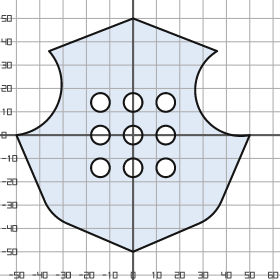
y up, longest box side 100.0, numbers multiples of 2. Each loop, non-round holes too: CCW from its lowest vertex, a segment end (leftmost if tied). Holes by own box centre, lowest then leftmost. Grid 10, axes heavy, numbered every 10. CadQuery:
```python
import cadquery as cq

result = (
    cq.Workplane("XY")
    .moveTo(0.0, -50.0)
    .lineTo(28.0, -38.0)
    .threePointArc((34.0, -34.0), (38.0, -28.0))
    .lineTo(50.0, 0.0)
    .threePointArc((28.0, 12.0), (36.0, 36.0))
    .lineTo(0.0, 50.0)
    .lineTo(-36.0, 36.0)
    .threePointArc((-32.0, 14.0), (-50.0, 0.0))
    .lineTo(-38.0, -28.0)
    .threePointArc((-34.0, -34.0), (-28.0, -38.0))
    .close()
    .moveTo(-14.0, -14.0)
    .circle(4.0)
    .moveTo(0.0, -14.0)
    .circle(4.0)
    .moveTo(14.0, -14.0)
    .circle(4.0)
    .moveTo(-14.0, 0.0)
    .circle(4.0)
    .moveTo(0.0, 0.0)
    .circle(4.0)
    .moveTo(14.0, 0.0)
    .circle(4.0)
    .moveTo(-14.0, 14.0)
    .circle(4.0)
    .moveTo(0.0, 14.0)
    .circle(4.0)
    .moveTo(14.0, 14.0)
    .circle(4.0)
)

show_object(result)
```